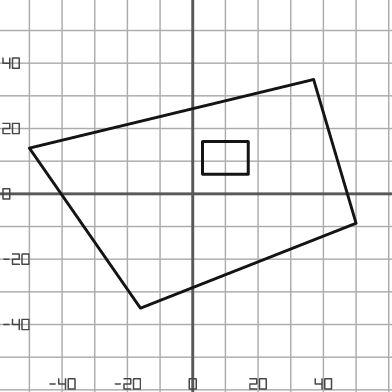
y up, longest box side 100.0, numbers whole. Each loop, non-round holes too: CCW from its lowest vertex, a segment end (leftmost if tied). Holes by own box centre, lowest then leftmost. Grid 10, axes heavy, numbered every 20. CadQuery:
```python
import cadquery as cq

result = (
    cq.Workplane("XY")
    .moveTo(-16.0, -35.0)
    .lineTo(50.0, -9.0)
    .lineTo(37.0, 35.0)
    .lineTo(-50.0, 14.0)
    .close()
    .moveTo(3.0, 6.0)
    .lineTo(17.0, 6.0)
    .lineTo(17.0, 16.0)
    .lineTo(3.0, 16.0)
    .close()
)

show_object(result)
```